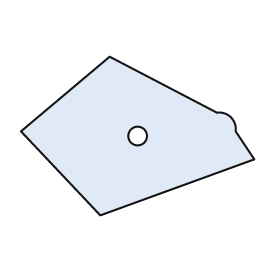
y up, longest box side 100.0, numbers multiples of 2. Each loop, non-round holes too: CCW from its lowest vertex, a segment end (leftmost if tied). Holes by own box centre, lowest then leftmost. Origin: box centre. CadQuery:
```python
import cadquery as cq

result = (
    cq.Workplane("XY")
    .moveTo(-16.0, -34.0)
    .lineTo(50.0, -10.0)
    .lineTo(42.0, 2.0)
    .threePointArc((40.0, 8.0), (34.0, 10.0))
    .lineTo(-12.0, 34.0)
    .lineTo(-50.0, 2.0)
    .close()
    .moveTo(0.0, 0.0)
    .circle(4.0)
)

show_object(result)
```